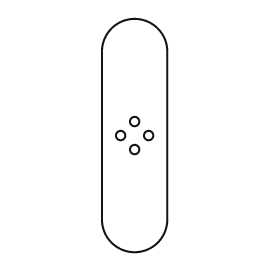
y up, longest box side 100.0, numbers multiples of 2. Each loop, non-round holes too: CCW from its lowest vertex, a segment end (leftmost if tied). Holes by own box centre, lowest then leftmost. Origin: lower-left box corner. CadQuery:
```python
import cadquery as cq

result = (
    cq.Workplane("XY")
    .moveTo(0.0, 14.0)
    .threePointArc((14.0, 0.0), (28.0, 14.0))
    .lineTo(28.0, 86.0)
    .threePointArc((14.0, 100.0), (0.0, 86.0))
    .close()
    .moveTo(14.0, 44.0)
    .circle(2.0)
    .moveTo(8.0, 50.0)
    .circle(2.0)
    .moveTo(20.0, 50.0)
    .circle(2.0)
    .moveTo(14.0, 56.0)
    .circle(2.0)
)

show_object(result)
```